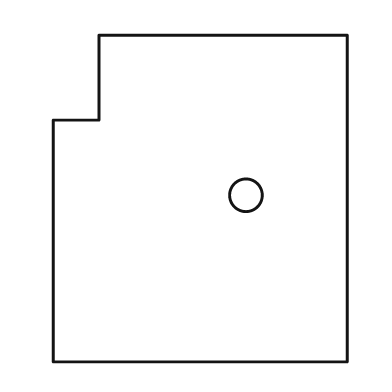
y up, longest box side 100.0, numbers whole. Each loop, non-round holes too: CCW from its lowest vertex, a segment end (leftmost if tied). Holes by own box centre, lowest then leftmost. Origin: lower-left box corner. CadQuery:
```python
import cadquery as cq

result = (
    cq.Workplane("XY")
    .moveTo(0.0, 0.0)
    .lineTo(90.0, 0.0)
    .lineTo(90.0, 100.0)
    .lineTo(14.0, 100.0)
    .lineTo(14.0, 74.0)
    .lineTo(0.0, 74.0)
    .close()
    .moveTo(59.0, 51.0)
    .circle(5.0)
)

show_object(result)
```